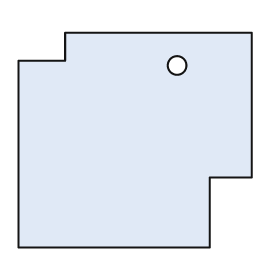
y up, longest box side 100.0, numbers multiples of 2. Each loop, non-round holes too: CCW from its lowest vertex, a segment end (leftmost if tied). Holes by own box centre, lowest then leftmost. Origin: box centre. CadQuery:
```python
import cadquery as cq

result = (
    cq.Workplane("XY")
    .moveTo(-50.0, -46.0)
    .lineTo(32.0, -46.0)
    .lineTo(32.0, -16.0)
    .lineTo(50.0, -16.0)
    .lineTo(50.0, 46.0)
    .lineTo(-30.0, 46.0)
    .lineTo(-30.0, 34.0)
    .lineTo(-50.0, 34.0)
    .close()
    .moveTo(18.0, 32.0)
    .circle(4.0)
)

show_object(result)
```